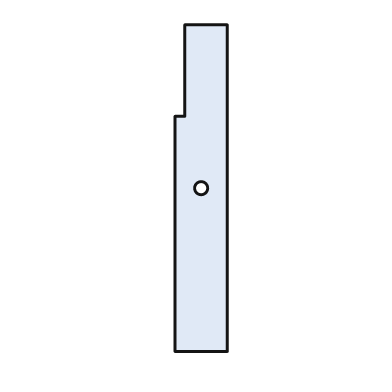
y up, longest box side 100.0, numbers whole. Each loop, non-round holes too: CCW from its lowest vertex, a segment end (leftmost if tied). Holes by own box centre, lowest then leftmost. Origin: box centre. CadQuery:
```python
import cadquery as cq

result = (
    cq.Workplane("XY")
    .moveTo(-8.0, -50.0)
    .lineTo(8.0, -50.0)
    .lineTo(8.0, 50.0)
    .lineTo(-5.0, 50.0)
    .lineTo(-5.0, 22.0)
    .lineTo(-8.0, 22.0)
    .close()
    .moveTo(0.0, 0.0)
    .circle(2.0)
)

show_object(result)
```